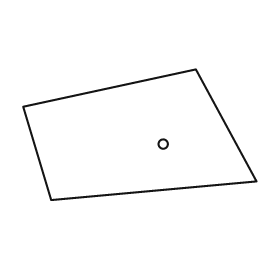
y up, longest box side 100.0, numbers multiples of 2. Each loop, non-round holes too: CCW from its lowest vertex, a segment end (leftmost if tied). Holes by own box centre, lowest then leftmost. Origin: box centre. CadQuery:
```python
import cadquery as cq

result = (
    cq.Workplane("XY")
    .moveTo(-38.0, -28.0)
    .lineTo(50.0, -20.0)
    .lineTo(24.0, 28.0)
    .lineTo(-50.0, 12.0)
    .close()
    .moveTo(10.0, -4.0)
    .circle(2.0)
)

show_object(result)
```